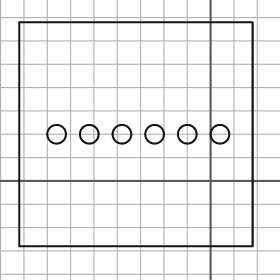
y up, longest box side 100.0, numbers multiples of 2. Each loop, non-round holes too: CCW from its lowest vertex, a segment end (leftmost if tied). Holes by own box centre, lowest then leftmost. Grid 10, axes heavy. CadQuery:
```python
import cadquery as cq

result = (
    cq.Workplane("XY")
    .moveTo(-82.0, -28.0)
    .lineTo(18.0, -28.0)
    .lineTo(18.0, 68.0)
    .lineTo(-82.0, 68.0)
    .close()
    .moveTo(-66.0, 20.0)
    .circle(4.0)
    .moveTo(-52.0, 20.0)
    .circle(4.0)
    .moveTo(-38.0, 20.0)
    .circle(4.0)
    .moveTo(-24.0, 20.0)
    .circle(4.0)
    .moveTo(-10.0, 20.0)
    .circle(4.0)
    .moveTo(4.0, 20.0)
    .circle(4.0)
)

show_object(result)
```